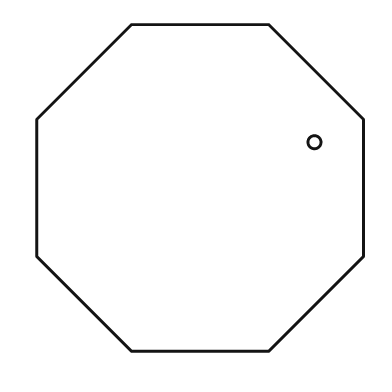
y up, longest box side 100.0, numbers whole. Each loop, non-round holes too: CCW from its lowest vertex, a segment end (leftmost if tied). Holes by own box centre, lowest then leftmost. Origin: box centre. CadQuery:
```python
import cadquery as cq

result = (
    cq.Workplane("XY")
    .moveTo(-21.0, -50.0)
    .lineTo(21.0, -50.0)
    .lineTo(50.0, -21.0)
    .lineTo(50.0, 21.0)
    .lineTo(21.0, 50.0)
    .lineTo(-21.0, 50.0)
    .lineTo(-50.0, 21.0)
    .lineTo(-50.0, -21.0)
    .close()
    .moveTo(35.0, 14.0)
    .circle(2.0)
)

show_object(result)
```